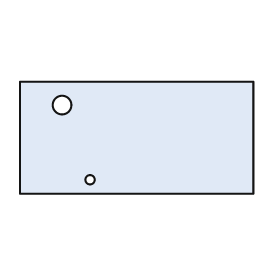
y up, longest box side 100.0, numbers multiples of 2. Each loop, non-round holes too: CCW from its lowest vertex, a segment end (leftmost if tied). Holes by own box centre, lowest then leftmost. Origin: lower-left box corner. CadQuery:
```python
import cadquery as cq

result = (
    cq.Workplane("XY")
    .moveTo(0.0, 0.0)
    .lineTo(100.0, 0.0)
    .lineTo(100.0, 48.0)
    .lineTo(0.0, 48.0)
    .close()
    .moveTo(30.0, 6.0)
    .circle(2.0)
    .moveTo(18.0, 38.0)
    .circle(4.0)
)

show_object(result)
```